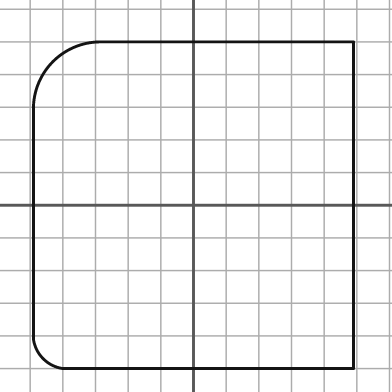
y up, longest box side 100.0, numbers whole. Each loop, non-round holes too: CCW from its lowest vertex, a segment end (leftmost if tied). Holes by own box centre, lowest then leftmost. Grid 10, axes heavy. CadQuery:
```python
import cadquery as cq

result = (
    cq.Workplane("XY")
    .moveTo(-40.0, -50.0)
    .lineTo(49.0, -50.0)
    .lineTo(49.0, 50.0)
    .lineTo(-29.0, 50.0)
    .threePointArc((-43.0, 44.0), (-49.0, 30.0))
    .lineTo(-49.0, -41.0)
    .threePointArc((-46.0, -47.0), (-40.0, -50.0))
    .close()
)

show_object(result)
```